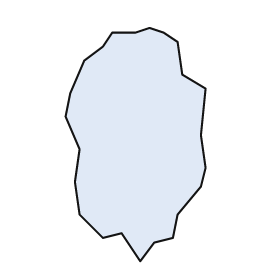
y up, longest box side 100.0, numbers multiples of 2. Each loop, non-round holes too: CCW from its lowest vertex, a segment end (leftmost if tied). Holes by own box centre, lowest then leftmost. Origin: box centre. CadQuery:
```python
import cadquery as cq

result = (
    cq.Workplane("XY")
    .moveTo(2.0, -50.0)
    .lineTo(8.0, -42.0)
    .lineTo(16.0, -40.0)
    .lineTo(18.0, -30.0)
    .lineTo(28.0, -18.0)
    .lineTo(30.0, -10.0)
    .lineTo(28.0, 4.0)
    .lineTo(30.0, 24.0)
    .lineTo(20.0, 30.0)
    .lineTo(18.0, 44.0)
    .lineTo(12.0, 48.0)
    .lineTo(6.0, 50.0)
    .lineTo(0.0, 48.0)
    .lineTo(-10.0, 48.0)
    .lineTo(-14.0, 42.0)
    .lineTo(-22.0, 36.0)
    .lineTo(-28.0, 22.0)
    .lineTo(-30.0, 12.0)
    .lineTo(-24.0, -2.0)
    .lineTo(-26.0, -16.0)
    .lineTo(-24.0, -30.0)
    .lineTo(-14.0, -40.0)
    .lineTo(-6.0, -38.0)
    .close()
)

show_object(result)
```